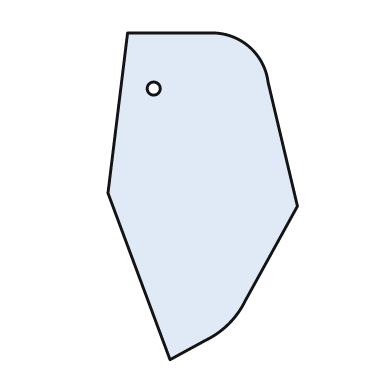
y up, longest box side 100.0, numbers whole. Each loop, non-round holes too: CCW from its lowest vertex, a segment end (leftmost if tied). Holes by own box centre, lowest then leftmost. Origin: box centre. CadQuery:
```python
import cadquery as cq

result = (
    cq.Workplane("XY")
    .moveTo(-10.0, -50.0)
    .lineTo(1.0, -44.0)
    .threePointArc((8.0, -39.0), (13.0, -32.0))
    .lineTo(29.0, -3.0)
    .lineTo(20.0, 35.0)
    .threePointArc((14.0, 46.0), (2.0, 50.0))
    .lineTo(-23.0, 50.0)
    .lineTo(-29.0, 1.0)
    .close()
    .moveTo(-15.0, 33.0)
    .circle(2.0)
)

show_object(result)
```